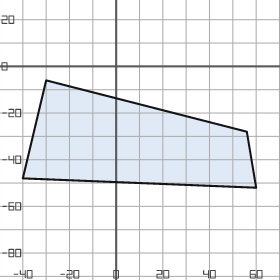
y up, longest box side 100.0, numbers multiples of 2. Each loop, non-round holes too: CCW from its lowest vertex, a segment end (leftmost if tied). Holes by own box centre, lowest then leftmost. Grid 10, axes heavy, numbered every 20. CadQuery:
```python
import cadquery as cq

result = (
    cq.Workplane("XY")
    .moveTo(60.0, -52.0)
    .lineTo(56.0, -28.0)
    .lineTo(-30.0, -6.0)
    .lineTo(-40.0, -48.0)
    .close()
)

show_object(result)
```